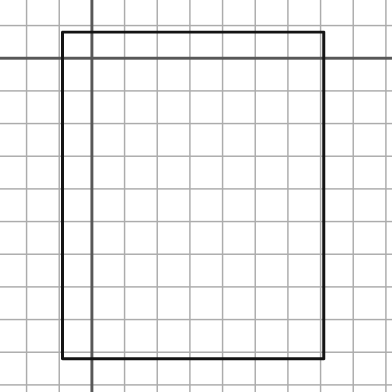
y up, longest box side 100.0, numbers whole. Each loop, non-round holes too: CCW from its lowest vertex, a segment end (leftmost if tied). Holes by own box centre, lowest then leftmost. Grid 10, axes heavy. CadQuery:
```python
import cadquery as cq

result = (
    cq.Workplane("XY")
    .moveTo(-9.0, -92.0)
    .lineTo(71.0, -92.0)
    .lineTo(71.0, 8.0)
    .lineTo(-9.0, 8.0)
    .close()
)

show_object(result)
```